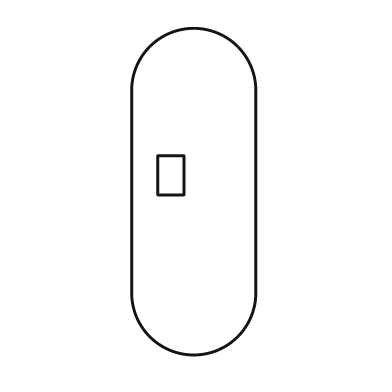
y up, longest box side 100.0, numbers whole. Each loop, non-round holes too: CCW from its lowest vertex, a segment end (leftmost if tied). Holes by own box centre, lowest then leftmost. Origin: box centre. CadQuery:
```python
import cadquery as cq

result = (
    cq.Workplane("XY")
    .moveTo(-19.0, -31.0)
    .threePointArc((0.0, -50.0), (19.0, -31.0))
    .lineTo(19.0, 31.0)
    .threePointArc((0.0, 50.0), (-19.0, 31.0))
    .close()
    .moveTo(-11.0, -1.0)
    .lineTo(-3.0, -1.0)
    .lineTo(-3.0, 11.0)
    .lineTo(-11.0, 11.0)
    .close()
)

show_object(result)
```